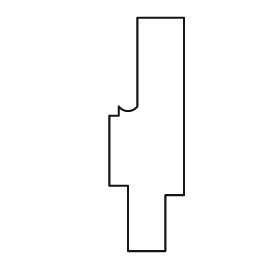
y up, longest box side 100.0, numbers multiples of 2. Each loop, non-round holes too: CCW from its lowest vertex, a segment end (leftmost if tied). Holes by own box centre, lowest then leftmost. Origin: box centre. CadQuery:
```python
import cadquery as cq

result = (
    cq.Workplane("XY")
    .moveTo(-8.0, -50.0)
    .lineTo(8.0, -50.0)
    .lineTo(8.0, -26.0)
    .lineTo(16.0, -26.0)
    .lineTo(16.0, 50.0)
    .lineTo(-4.0, 50.0)
    .lineTo(-4.0, 12.0)
    .threePointArc((-8.0, 10.0), (-12.0, 12.0))
    .lineTo(-12.0, 8.0)
    .lineTo(-16.0, 8.0)
    .lineTo(-16.0, -22.0)
    .lineTo(-8.0, -22.0)
    .close()
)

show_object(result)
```